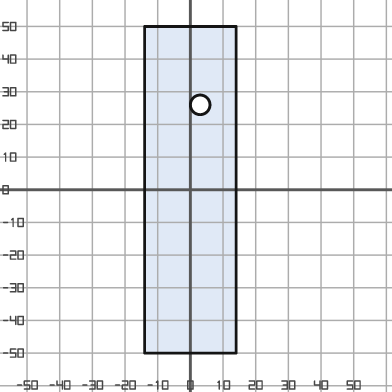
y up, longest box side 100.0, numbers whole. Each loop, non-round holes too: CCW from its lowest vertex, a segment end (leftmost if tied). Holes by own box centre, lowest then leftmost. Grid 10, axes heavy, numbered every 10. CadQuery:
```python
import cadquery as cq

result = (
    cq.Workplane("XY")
    .moveTo(-14.0, -50.0)
    .lineTo(14.0, -50.0)
    .lineTo(14.0, 50.0)
    .lineTo(-14.0, 50.0)
    .close()
    .moveTo(3.0, 26.0)
    .circle(3.0)
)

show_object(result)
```